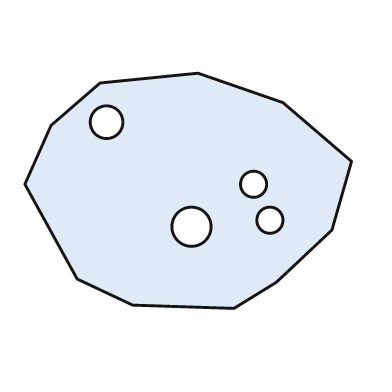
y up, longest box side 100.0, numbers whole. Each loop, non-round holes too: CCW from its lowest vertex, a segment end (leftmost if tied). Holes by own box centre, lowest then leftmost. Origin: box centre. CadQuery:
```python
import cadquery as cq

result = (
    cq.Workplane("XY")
    .moveTo(14.0, -36.0)
    .lineTo(27.0, -28.0)
    .lineTo(44.0, -12.0)
    .lineTo(50.0, 9.0)
    .lineTo(29.0, 27.0)
    .lineTo(3.0, 36.0)
    .lineTo(-27.0, 33.0)
    .lineTo(-42.0, 20.0)
    .lineTo(-50.0, 2.0)
    .lineTo(-34.0, -27.0)
    .lineTo(-17.0, -35.0)
    .close()
    .moveTo(1.0, -11.0)
    .circle(6.0)
    .moveTo(25.0, -9.0)
    .circle(4.0)
    .moveTo(20.0, 2.0)
    .circle(4.0)
    .moveTo(-25.0, 21.0)
    .circle(5.0)
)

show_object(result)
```